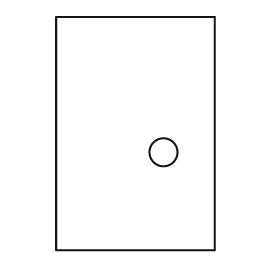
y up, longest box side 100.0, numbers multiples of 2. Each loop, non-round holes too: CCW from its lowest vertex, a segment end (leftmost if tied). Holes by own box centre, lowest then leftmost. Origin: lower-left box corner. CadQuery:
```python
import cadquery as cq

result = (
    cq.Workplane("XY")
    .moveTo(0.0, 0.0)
    .lineTo(68.0, 0.0)
    .lineTo(68.0, 100.0)
    .lineTo(0.0, 100.0)
    .close()
    .moveTo(46.0, 42.0)
    .circle(6.0)
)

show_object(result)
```